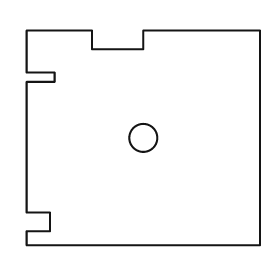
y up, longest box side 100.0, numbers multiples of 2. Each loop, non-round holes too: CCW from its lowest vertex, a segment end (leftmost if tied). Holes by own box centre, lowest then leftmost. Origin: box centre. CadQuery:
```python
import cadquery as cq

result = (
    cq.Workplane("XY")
    .moveTo(-50.0, -46.0)
    .lineTo(50.0, -46.0)
    .lineTo(50.0, 46.0)
    .lineTo(0.0, 46.0)
    .lineTo(0.0, 38.0)
    .lineTo(-22.0, 38.0)
    .lineTo(-22.0, 46.0)
    .lineTo(-50.0, 46.0)
    .lineTo(-50.0, 28.0)
    .lineTo(-38.0, 28.0)
    .lineTo(-38.0, 24.0)
    .lineTo(-50.0, 24.0)
    .lineTo(-50.0, -32.0)
    .lineTo(-40.0, -32.0)
    .lineTo(-40.0, -40.0)
    .lineTo(-50.0, -40.0)
    .close()
    .moveTo(0.0, 0.0)
    .circle(6.0)
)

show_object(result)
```